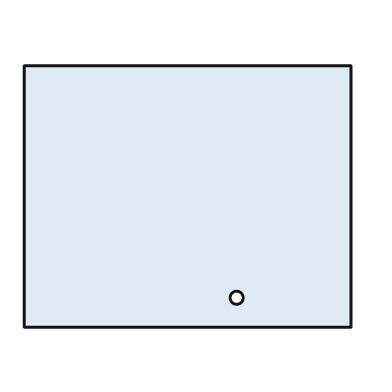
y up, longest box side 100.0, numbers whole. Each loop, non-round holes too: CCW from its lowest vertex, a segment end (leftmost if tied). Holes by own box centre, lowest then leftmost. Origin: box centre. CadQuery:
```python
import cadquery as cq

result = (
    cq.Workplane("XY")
    .moveTo(-50.0, -40.0)
    .lineTo(50.0, -40.0)
    .lineTo(50.0, 40.0)
    .lineTo(-50.0, 40.0)
    .close()
    .moveTo(15.0, -31.0)
    .circle(2.0)
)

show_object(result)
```